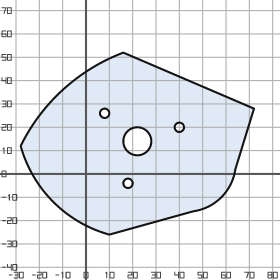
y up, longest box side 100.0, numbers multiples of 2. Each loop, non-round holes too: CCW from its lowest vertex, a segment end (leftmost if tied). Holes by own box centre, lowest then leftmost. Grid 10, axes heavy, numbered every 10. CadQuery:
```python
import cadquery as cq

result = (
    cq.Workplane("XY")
    .moveTo(10.0, -26.0)
    .lineTo(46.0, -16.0)
    .threePointArc((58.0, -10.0), (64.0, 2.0))
    .lineTo(72.0, 28.0)
    .lineTo(16.0, 52.0)
    .threePointArc((-10.0, 36.0), (-28.0, 12.0))
    .threePointArc((-14.0, -12.0), (10.0, -26.0))
    .close()
    .moveTo(18.0, -4.0)
    .circle(2.0)
    .moveTo(22.0, 14.0)
    .circle(6.0)
    .moveTo(40.0, 20.0)
    .circle(2.0)
    .moveTo(8.0, 26.0)
    .circle(2.0)
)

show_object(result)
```